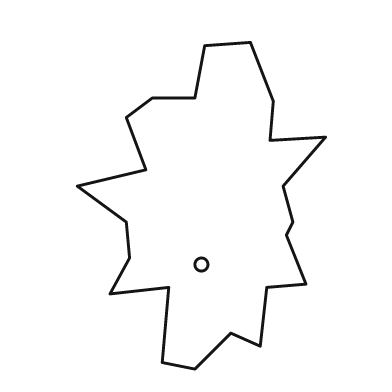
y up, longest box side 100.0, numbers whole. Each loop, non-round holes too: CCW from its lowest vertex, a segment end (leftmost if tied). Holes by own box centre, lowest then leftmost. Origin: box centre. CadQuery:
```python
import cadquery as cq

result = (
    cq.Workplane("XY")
    .moveTo(-2.0, -50.0)
    .lineTo(9.0, -39.0)
    .lineTo(18.0, -43.0)
    .lineTo(20.0, -25.0)
    .lineTo(32.0, -24.0)
    .lineTo(26.0, -9.0)
    .lineTo(28.0, -5.0)
    .lineTo(25.0, 6.0)
    .lineTo(38.0, 21.0)
    .lineTo(21.0, 20.0)
    .lineTo(22.0, 32.0)
    .lineTo(15.0, 50.0)
    .lineTo(1.0, 49.0)
    .lineTo(-2.0, 33.0)
    .lineTo(-15.0, 33.0)
    .lineTo(-23.0, 27.0)
    .lineTo(-17.0, 11.0)
    .lineTo(-38.0, 6.0)
    .lineTo(-23.0, -5.0)
    .lineTo(-22.0, -16.0)
    .lineTo(-28.0, -27.0)
    .lineTo(-10.0, -25.0)
    .lineTo(-12.0, -48.0)
    .close()
    .moveTo(0.0, -18.0)
    .circle(2.0)
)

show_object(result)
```